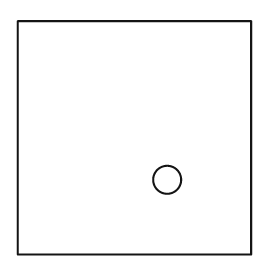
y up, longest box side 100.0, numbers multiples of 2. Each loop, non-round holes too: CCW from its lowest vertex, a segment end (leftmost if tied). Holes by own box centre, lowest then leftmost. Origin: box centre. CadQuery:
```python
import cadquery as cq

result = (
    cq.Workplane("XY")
    .moveTo(-50.0, -50.0)
    .lineTo(50.0, -50.0)
    .lineTo(50.0, 50.0)
    .lineTo(-50.0, 50.0)
    .close()
    .moveTo(14.0, -18.0)
    .circle(6.0)
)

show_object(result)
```